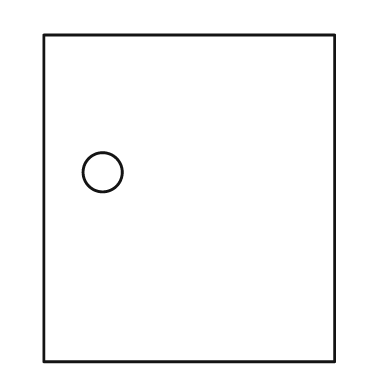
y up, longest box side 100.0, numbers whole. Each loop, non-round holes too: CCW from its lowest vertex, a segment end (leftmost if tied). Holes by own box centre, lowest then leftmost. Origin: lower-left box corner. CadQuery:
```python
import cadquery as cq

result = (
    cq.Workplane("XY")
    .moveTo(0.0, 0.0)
    .lineTo(89.0, 0.0)
    .lineTo(89.0, 100.0)
    .lineTo(0.0, 100.0)
    .close()
    .moveTo(18.0, 58.0)
    .circle(6.0)
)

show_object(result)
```